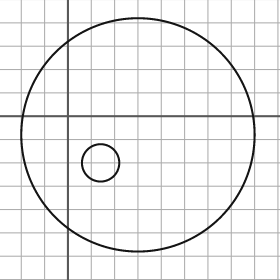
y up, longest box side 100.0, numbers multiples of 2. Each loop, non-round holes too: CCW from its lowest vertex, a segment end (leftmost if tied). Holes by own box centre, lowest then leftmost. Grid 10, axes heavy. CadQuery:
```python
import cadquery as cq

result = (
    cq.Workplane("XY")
    .moveTo(30.0, -8.0)
    .circle(50.0)
    .moveTo(14.0, -20.0)
    .circle(8.0)
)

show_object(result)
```